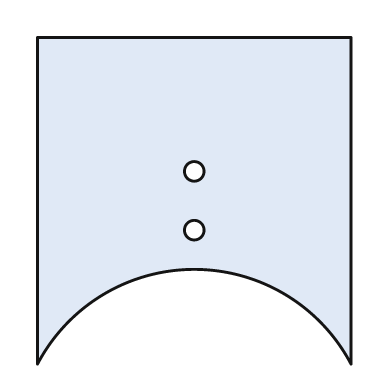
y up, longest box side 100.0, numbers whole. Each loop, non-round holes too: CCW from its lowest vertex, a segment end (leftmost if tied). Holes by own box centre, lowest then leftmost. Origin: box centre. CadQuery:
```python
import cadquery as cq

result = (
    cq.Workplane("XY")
    .moveTo(-48.0, -50.0)
    .threePointArc((0.0, -21.0), (48.0, -50.0))
    .lineTo(48.0, 50.0)
    .lineTo(-48.0, 50.0)
    .close()
    .moveTo(0.0, -9.0)
    .circle(3.0)
    .moveTo(0.0, 9.0)
    .circle(3.0)
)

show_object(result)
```